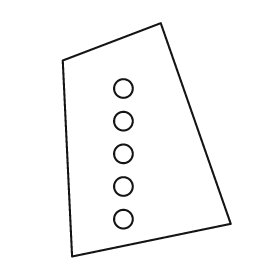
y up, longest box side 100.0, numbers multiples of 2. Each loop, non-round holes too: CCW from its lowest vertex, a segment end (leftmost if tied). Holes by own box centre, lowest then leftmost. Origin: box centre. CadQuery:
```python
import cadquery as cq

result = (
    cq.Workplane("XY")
    .moveTo(-32.0, -50.0)
    .lineTo(36.0, -36.0)
    .lineTo(6.0, 50.0)
    .lineTo(-36.0, 34.0)
    .close()
    .moveTo(-10.0, -34.0)
    .circle(4.0)
    .moveTo(-10.0, -20.0)
    .circle(4.0)
    .moveTo(-10.0, -6.0)
    .circle(4.0)
    .moveTo(-10.0, 8.0)
    .circle(4.0)
    .moveTo(-10.0, 22.0)
    .circle(4.0)
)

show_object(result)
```